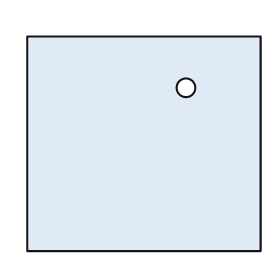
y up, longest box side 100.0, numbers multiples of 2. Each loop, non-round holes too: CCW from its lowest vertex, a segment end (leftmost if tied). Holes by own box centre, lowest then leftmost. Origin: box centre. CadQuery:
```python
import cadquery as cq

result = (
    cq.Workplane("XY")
    .moveTo(-50.0, -46.0)
    .lineTo(50.0, -46.0)
    .lineTo(50.0, 46.0)
    .lineTo(-50.0, 46.0)
    .close()
    .moveTo(18.0, 24.0)
    .circle(4.0)
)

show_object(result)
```